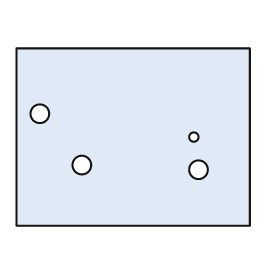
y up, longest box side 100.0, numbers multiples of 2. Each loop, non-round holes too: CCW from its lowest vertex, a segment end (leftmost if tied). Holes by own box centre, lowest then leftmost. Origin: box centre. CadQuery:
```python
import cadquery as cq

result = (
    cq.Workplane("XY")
    .moveTo(-50.0, -38.0)
    .lineTo(50.0, -38.0)
    .lineTo(50.0, 38.0)
    .lineTo(-50.0, 38.0)
    .close()
    .moveTo(28.0, -14.0)
    .circle(4.0)
    .moveTo(-22.0, -12.0)
    .circle(4.0)
    .moveTo(26.0, 0.0)
    .circle(2.0)
    .moveTo(-40.0, 10.0)
    .circle(4.0)
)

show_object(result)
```